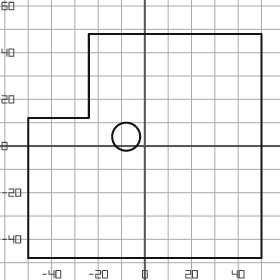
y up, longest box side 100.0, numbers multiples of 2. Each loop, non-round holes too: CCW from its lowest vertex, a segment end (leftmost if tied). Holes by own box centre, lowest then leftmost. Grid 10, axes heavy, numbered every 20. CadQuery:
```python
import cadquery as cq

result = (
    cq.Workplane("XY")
    .moveTo(-50.0, -48.0)
    .lineTo(50.0, -48.0)
    .lineTo(50.0, 48.0)
    .lineTo(-24.0, 48.0)
    .lineTo(-24.0, 12.0)
    .lineTo(-50.0, 12.0)
    .close()
    .moveTo(-8.0, 4.0)
    .circle(6.0)
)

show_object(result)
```